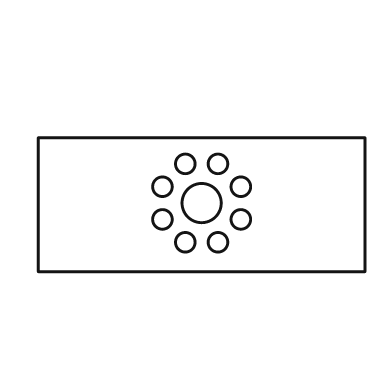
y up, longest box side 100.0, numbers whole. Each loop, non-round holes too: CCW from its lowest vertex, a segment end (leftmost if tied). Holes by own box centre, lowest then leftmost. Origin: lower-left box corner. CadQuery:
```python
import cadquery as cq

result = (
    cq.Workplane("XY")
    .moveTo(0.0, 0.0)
    .lineTo(100.0, 0.0)
    .lineTo(100.0, 41.0)
    .lineTo(0.0, 41.0)
    .close()
    .moveTo(45.0, 9.0)
    .circle(3.0)
    .moveTo(55.0, 9.0)
    .circle(3.0)
    .moveTo(38.0, 16.0)
    .circle(3.0)
    .moveTo(62.0, 16.0)
    .circle(3.0)
    .moveTo(50.0, 21.0)
    .circle(6.0)
    .moveTo(38.0, 26.0)
    .circle(3.0)
    .moveTo(62.0, 26.0)
    .circle(3.0)
    .moveTo(45.0, 33.0)
    .circle(3.0)
    .moveTo(55.0, 33.0)
    .circle(3.0)
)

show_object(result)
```